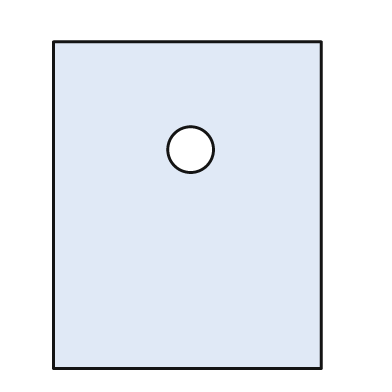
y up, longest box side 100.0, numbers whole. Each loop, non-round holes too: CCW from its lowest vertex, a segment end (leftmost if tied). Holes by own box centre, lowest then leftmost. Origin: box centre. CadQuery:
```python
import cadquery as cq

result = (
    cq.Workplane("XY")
    .moveTo(-41.0, -50.0)
    .lineTo(41.0, -50.0)
    .lineTo(41.0, 50.0)
    .lineTo(-41.0, 50.0)
    .close()
    .moveTo(1.0, 17.0)
    .circle(7.0)
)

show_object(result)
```